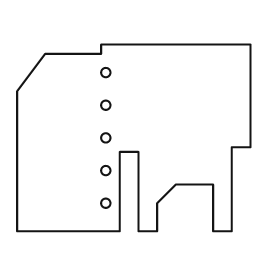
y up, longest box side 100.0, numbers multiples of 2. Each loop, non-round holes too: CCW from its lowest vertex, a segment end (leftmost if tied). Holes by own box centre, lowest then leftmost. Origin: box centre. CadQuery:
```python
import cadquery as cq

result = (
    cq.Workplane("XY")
    .moveTo(-50.0, -40.0)
    .lineTo(-6.0, -40.0)
    .lineTo(-6.0, -6.0)
    .lineTo(2.0, -6.0)
    .lineTo(2.0, -40.0)
    .lineTo(10.0, -40.0)
    .lineTo(10.0, -28.0)
    .lineTo(18.0, -20.0)
    .lineTo(34.0, -20.0)
    .lineTo(34.0, -40.0)
    .lineTo(42.0, -40.0)
    .lineTo(42.0, -4.0)
    .lineTo(50.0, -4.0)
    .lineTo(50.0, 40.0)
    .lineTo(-14.0, 40.0)
    .lineTo(-14.0, 36.0)
    .lineTo(-38.0, 36.0)
    .lineTo(-50.0, 20.0)
    .close()
    .moveTo(-12.0, -28.0)
    .circle(2.0)
    .moveTo(-12.0, -14.0)
    .circle(2.0)
    .moveTo(-12.0, 0.0)
    .circle(2.0)
    .moveTo(-12.0, 14.0)
    .circle(2.0)
    .moveTo(-12.0, 28.0)
    .circle(2.0)
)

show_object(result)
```